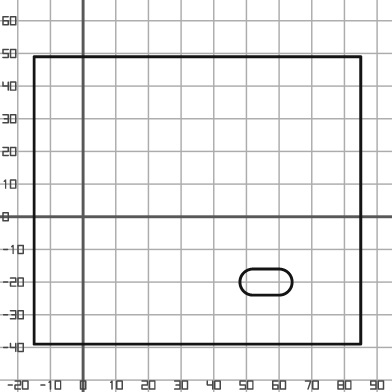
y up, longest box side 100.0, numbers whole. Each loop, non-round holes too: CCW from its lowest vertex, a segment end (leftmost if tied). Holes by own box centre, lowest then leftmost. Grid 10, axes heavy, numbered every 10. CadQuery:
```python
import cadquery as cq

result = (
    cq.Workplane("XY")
    .moveTo(-15.0, -39.0)
    .lineTo(85.0, -39.0)
    .lineTo(85.0, 49.0)
    .lineTo(-15.0, 49.0)
    .close()
    .moveTo(52.0, -24.0)
    .lineTo(60.0, -24.0)
    .threePointArc((64.0, -20.0), (60.0, -16.0))
    .lineTo(52.0, -16.0)
    .threePointArc((48.0, -20.0), (52.0, -24.0))
    .close()
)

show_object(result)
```